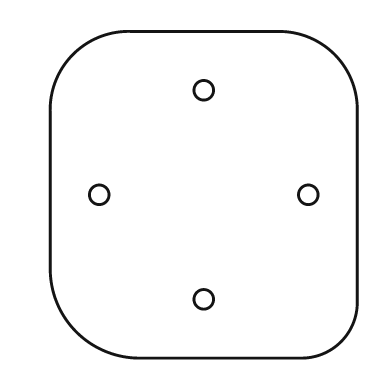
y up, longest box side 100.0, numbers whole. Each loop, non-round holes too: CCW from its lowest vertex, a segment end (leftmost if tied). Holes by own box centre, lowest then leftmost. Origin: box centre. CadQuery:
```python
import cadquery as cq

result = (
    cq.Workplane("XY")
    .moveTo(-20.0, -50.0)
    .lineTo(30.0, -50.0)
    .threePointArc((42.0, -45.0), (47.0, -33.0))
    .lineTo(47.0, 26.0)
    .threePointArc((40.0, 43.0), (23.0, 50.0))
    .lineTo(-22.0, 50.0)
    .threePointArc((-40.0, 43.0), (-47.0, 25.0))
    .lineTo(-47.0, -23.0)
    .threePointArc((-39.0, -42.0), (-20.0, -50.0))
    .close()
    .moveTo(0.0, -32.0)
    .circle(3.0)
    .moveTo(-32.0, 0.0)
    .circle(3.0)
    .moveTo(32.0, 0.0)
    .circle(3.0)
    .moveTo(0.0, 32.0)
    .circle(3.0)
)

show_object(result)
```